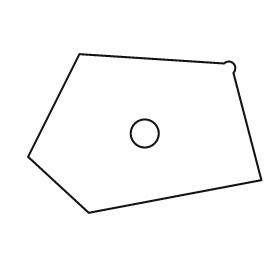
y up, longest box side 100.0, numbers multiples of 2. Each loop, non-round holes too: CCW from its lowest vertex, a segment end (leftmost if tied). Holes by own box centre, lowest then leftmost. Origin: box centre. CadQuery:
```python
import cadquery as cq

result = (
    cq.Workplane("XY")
    .moveTo(-24.0, -34.0)
    .lineTo(50.0, -20.0)
    .lineTo(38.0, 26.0)
    .threePointArc((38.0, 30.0), (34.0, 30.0))
    .lineTo(-28.0, 34.0)
    .lineTo(-50.0, -10.0)
    .close()
    .moveTo(0.0, 0.0)
    .circle(6.0)
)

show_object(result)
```